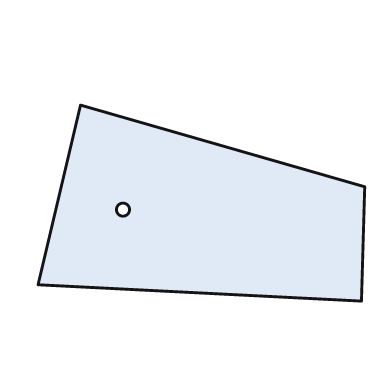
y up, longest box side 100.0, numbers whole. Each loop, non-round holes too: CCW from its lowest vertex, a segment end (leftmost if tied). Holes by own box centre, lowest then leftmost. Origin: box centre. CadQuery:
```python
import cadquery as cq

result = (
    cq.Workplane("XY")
    .moveTo(49.0, -30.0)
    .lineTo(50.0, 5.0)
    .lineTo(-37.0, 30.0)
    .lineTo(-50.0, -25.0)
    .close()
    .moveTo(-24.0, -2.0)
    .circle(2.0)
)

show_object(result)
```